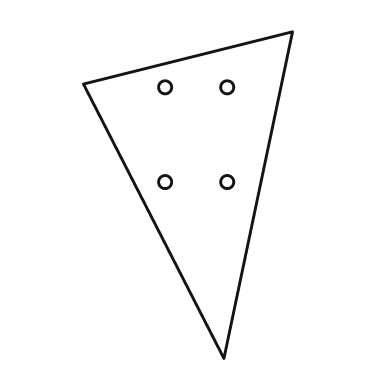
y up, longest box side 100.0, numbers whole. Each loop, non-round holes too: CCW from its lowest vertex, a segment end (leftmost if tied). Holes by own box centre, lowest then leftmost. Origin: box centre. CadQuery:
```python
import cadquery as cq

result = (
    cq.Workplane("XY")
    .moveTo(11.0, -50.0)
    .lineTo(32.0, 50.0)
    .lineTo(-32.0, 34.0)
    .close()
    .moveTo(-7.0, 4.0)
    .circle(2.0)
    .moveTo(12.0, 4.0)
    .circle(2.0)
    .moveTo(-7.0, 33.0)
    .circle(2.0)
    .moveTo(12.0, 33.0)
    .circle(2.0)
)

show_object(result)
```